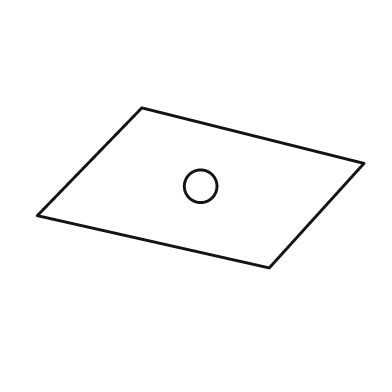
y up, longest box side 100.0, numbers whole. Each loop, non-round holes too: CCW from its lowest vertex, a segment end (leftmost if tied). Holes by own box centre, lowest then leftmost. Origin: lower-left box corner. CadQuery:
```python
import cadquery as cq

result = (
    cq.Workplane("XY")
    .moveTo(71.0, 0.0)
    .lineTo(100.0, 32.0)
    .lineTo(32.0, 49.0)
    .lineTo(0.0, 16.0)
    .close()
    .moveTo(50.0, 25.0)
    .circle(5.0)
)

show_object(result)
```